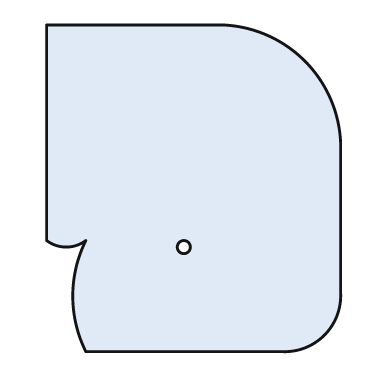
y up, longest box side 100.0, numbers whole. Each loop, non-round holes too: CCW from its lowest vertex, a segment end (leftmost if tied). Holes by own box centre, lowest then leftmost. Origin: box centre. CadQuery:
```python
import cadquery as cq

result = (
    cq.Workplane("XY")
    .moveTo(-33.0, -50.0)
    .lineTo(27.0, -50.0)
    .threePointArc((40.0, -45.0), (45.0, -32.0))
    .lineTo(45.0, 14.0)
    .threePointArc((34.0, 39.0), (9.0, 50.0))
    .lineTo(-45.0, 50.0)
    .lineTo(-45.0, -16.0)
    .threePointArc((-39.0, -18.0), (-33.0, -16.0))
    .threePointArc((-37.0, -33.0), (-33.0, -50.0))
    .close()
    .moveTo(-3.0, -18.0)
    .circle(2.0)
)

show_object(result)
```